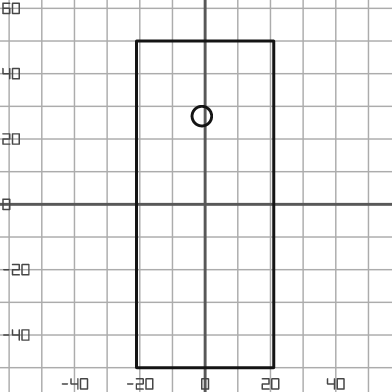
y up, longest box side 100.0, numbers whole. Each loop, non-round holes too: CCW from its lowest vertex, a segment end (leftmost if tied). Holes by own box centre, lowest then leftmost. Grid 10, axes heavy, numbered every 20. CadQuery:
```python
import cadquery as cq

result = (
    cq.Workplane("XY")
    .moveTo(-21.0, -50.0)
    .lineTo(21.0, -50.0)
    .lineTo(21.0, 50.0)
    .lineTo(-21.0, 50.0)
    .close()
    .moveTo(-1.0, 27.0)
    .circle(3.0)
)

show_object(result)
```